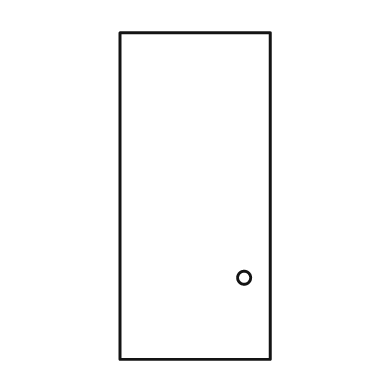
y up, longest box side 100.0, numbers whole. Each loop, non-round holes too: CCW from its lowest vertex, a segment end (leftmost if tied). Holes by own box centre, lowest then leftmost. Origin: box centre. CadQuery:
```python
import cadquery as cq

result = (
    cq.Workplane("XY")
    .moveTo(-23.0, -50.0)
    .lineTo(23.0, -50.0)
    .lineTo(23.0, 50.0)
    .lineTo(-23.0, 50.0)
    .close()
    .moveTo(15.0, -25.0)
    .circle(2.0)
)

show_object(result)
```